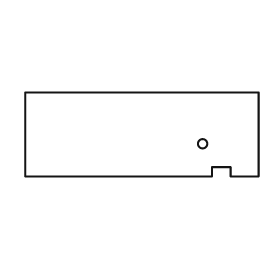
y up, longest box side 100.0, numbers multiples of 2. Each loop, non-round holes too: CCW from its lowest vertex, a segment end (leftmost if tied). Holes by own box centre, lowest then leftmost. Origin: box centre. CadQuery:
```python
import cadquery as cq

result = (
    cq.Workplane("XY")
    .moveTo(-50.0, -18.0)
    .lineTo(30.0, -18.0)
    .lineTo(30.0, -14.0)
    .lineTo(38.0, -14.0)
    .lineTo(38.0, -18.0)
    .lineTo(50.0, -18.0)
    .lineTo(50.0, 18.0)
    .lineTo(-50.0, 18.0)
    .close()
    .moveTo(26.0, -4.0)
    .circle(2.0)
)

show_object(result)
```